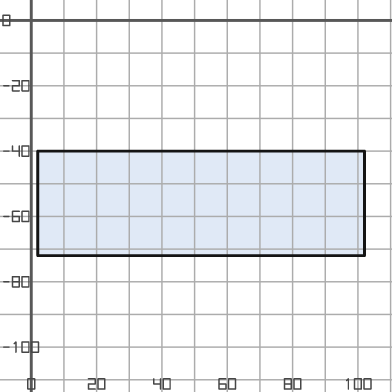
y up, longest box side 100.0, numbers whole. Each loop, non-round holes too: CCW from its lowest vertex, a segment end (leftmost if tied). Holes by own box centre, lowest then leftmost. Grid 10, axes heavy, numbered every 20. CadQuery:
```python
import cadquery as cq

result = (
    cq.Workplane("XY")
    .moveTo(2.0, -72.0)
    .lineTo(102.0, -72.0)
    .lineTo(102.0, -40.0)
    .lineTo(2.0, -40.0)
    .close()
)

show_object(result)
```